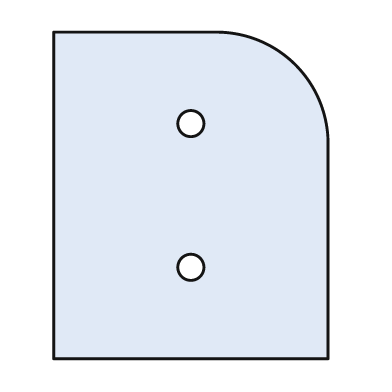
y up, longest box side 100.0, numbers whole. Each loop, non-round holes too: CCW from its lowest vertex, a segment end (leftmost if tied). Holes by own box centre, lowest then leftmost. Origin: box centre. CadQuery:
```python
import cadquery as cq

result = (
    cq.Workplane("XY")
    .moveTo(-42.0, -50.0)
    .lineTo(42.0, -50.0)
    .lineTo(42.0, 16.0)
    .threePointArc((32.0, 40.0), (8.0, 50.0))
    .lineTo(-42.0, 50.0)
    .close()
    .moveTo(0.0, -22.0)
    .circle(4.0)
    .moveTo(0.0, 22.0)
    .circle(4.0)
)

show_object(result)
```